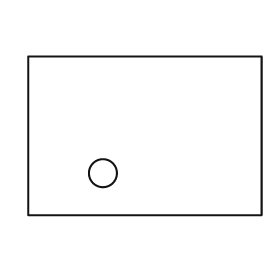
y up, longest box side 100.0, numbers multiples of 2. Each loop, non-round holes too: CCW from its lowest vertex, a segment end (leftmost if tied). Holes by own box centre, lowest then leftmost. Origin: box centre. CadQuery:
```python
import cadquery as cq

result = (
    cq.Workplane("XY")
    .moveTo(-50.0, -34.0)
    .lineTo(50.0, -34.0)
    .lineTo(50.0, 34.0)
    .lineTo(-50.0, 34.0)
    .close()
    .moveTo(-18.0, -16.0)
    .circle(6.0)
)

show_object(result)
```